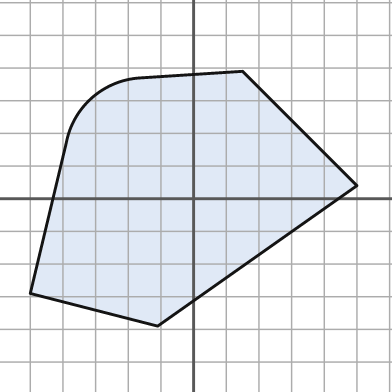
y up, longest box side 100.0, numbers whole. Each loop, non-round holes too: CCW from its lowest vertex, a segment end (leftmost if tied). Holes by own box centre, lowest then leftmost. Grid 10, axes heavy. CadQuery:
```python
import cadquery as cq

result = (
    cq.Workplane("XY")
    .moveTo(-11.0, -39.0)
    .lineTo(50.0, 4.0)
    .lineTo(15.0, 39.0)
    .lineTo(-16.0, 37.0)
    .threePointArc((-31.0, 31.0), (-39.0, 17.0))
    .lineTo(-50.0, -29.0)
    .close()
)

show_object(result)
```